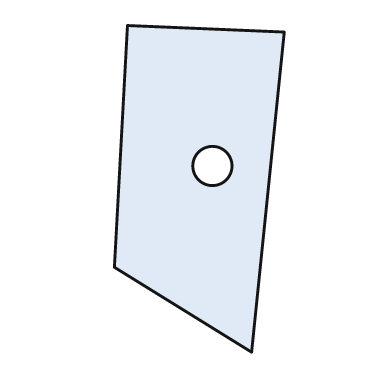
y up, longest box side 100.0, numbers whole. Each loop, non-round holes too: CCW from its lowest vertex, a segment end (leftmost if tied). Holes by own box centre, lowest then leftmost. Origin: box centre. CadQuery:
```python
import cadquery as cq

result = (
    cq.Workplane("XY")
    .moveTo(16.0, -50.0)
    .lineTo(26.0, 48.0)
    .lineTo(-22.0, 50.0)
    .lineTo(-26.0, -24.0)
    .close()
    .moveTo(4.0, 7.0)
    .circle(6.0)
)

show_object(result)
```